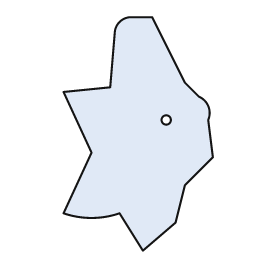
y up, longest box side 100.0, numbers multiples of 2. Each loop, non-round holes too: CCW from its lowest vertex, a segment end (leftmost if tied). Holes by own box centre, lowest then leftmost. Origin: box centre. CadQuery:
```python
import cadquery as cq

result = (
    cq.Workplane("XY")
    .moveTo(2.0, -50.0)
    .lineTo(16.0, -38.0)
    .lineTo(20.0, -22.0)
    .lineTo(32.0, -10.0)
    .lineTo(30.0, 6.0)
    .threePointArc((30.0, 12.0), (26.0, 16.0))
    .lineTo(20.0, 22.0)
    .lineTo(6.0, 50.0)
    .lineTo(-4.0, 50.0)
    .threePointArc((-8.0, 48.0), (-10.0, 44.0))
    .lineTo(-12.0, 20.0)
    .lineTo(-32.0, 18.0)
    .lineTo(-20.0, -8.0)
    .lineTo(-32.0, -34.0)
    .threePointArc((-20.0, -36.0), (-8.0, -34.0))
    .close()
    .moveTo(12.0, 6.0)
    .circle(2.0)
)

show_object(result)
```